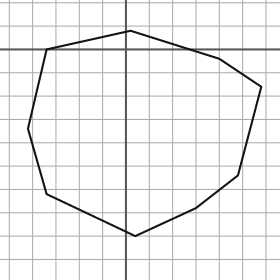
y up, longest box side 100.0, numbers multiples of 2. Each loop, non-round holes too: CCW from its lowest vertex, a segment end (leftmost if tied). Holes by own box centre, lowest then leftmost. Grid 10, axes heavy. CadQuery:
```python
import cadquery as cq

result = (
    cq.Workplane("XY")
    .moveTo(4.0, -80.0)
    .lineTo(30.0, -68.0)
    .lineTo(48.0, -54.0)
    .lineTo(58.0, -16.0)
    .lineTo(40.0, -4.0)
    .lineTo(2.0, 8.0)
    .lineTo(-34.0, 0.0)
    .lineTo(-42.0, -34.0)
    .lineTo(-34.0, -62.0)
    .close()
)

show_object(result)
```